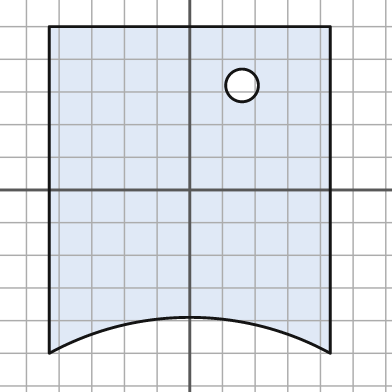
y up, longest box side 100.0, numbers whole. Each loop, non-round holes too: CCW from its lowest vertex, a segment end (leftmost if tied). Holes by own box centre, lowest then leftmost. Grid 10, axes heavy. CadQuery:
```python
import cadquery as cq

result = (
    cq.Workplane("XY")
    .moveTo(-43.0, -50.0)
    .threePointArc((0.0, -39.0), (43.0, -50.0))
    .lineTo(43.0, 50.0)
    .lineTo(-43.0, 50.0)
    .close()
    .moveTo(16.0, 32.0)
    .circle(5.0)
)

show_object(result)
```